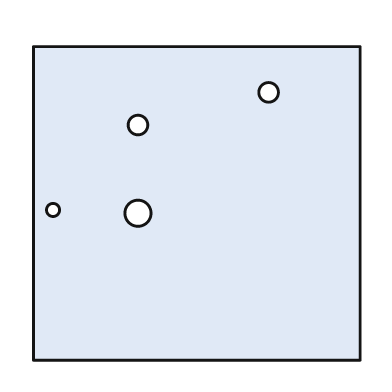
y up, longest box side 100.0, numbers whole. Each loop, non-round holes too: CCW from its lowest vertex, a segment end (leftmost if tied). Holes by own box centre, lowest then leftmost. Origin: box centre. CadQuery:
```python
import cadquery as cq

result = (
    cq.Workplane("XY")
    .moveTo(-50.0, -48.0)
    .lineTo(50.0, -48.0)
    .lineTo(50.0, 48.0)
    .lineTo(-50.0, 48.0)
    .close()
    .moveTo(-18.0, -3.0)
    .circle(4.0)
    .moveTo(-44.0, -2.0)
    .circle(2.0)
    .moveTo(-18.0, 24.0)
    .circle(3.0)
    .moveTo(22.0, 34.0)
    .circle(3.0)
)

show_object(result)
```